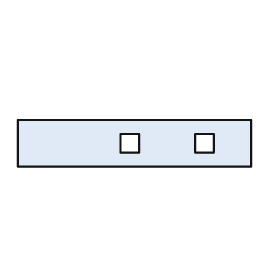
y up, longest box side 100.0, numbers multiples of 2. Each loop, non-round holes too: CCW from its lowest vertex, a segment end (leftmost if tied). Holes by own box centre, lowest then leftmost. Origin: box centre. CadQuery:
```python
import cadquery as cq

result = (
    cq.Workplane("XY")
    .moveTo(-50.0, -10.0)
    .lineTo(50.0, -10.0)
    .lineTo(50.0, 10.0)
    .lineTo(-50.0, 10.0)
    .close()
    .moveTo(-6.0, -4.0)
    .lineTo(2.0, -4.0)
    .lineTo(2.0, 4.0)
    .lineTo(-6.0, 4.0)
    .close()
    .moveTo(26.0, -4.0)
    .lineTo(34.0, -4.0)
    .lineTo(34.0, 4.0)
    .lineTo(26.0, 4.0)
    .close()
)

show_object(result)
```